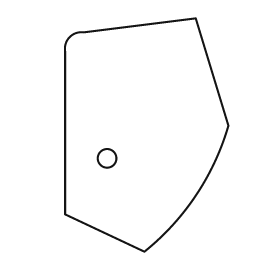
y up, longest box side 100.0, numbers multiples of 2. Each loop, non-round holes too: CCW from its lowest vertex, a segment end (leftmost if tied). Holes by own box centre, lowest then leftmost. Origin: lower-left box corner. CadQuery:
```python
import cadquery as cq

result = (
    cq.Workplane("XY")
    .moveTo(34.0, 0.0)
    .threePointArc((56.0, 24.0), (70.0, 54.0))
    .lineTo(56.0, 100.0)
    .lineTo(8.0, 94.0)
    .threePointArc((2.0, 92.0), (0.0, 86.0))
    .lineTo(0.0, 16.0)
    .close()
    .moveTo(18.0, 40.0)
    .circle(4.0)
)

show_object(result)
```